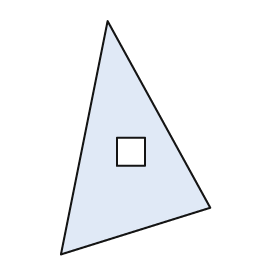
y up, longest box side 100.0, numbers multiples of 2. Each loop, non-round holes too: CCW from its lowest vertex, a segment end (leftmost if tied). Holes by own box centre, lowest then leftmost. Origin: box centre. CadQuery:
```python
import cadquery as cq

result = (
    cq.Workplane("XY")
    .moveTo(-32.0, -50.0)
    .lineTo(32.0, -30.0)
    .lineTo(-12.0, 50.0)
    .close()
    .moveTo(-8.0, -12.0)
    .lineTo(4.0, -12.0)
    .lineTo(4.0, 0.0)
    .lineTo(-8.0, 0.0)
    .close()
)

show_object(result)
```